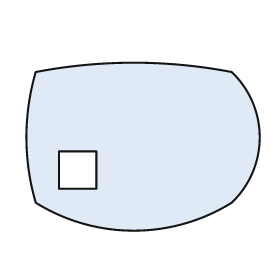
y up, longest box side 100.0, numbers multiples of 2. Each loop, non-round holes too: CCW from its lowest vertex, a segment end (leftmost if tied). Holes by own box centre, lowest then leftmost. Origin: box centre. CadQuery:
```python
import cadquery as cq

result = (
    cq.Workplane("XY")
    .moveTo(-46.0, -24.0)
    .threePointArc((-4.0, -36.0), (38.0, -24.0))
    .threePointArc((50.0, 4.0), (38.0, 32.0))
    .threePointArc((-4.0, 36.0), (-46.0, 32.0))
    .threePointArc((-50.0, 4.0), (-46.0, -24.0))
    .close()
    .moveTo(-36.0, -18.0)
    .lineTo(-20.0, -18.0)
    .lineTo(-20.0, -2.0)
    .lineTo(-36.0, -2.0)
    .close()
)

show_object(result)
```